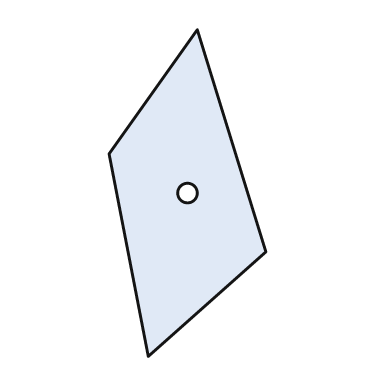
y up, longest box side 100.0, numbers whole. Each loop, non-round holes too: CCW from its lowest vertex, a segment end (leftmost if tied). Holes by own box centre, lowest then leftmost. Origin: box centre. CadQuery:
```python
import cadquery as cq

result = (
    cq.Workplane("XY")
    .moveTo(-12.0, -50.0)
    .lineTo(24.0, -18.0)
    .lineTo(3.0, 50.0)
    .lineTo(-24.0, 12.0)
    .close()
    .moveTo(0.0, 0.0)
    .circle(3.0)
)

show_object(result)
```